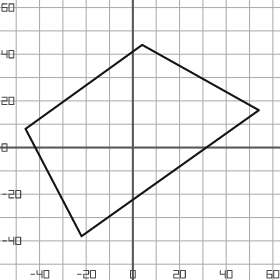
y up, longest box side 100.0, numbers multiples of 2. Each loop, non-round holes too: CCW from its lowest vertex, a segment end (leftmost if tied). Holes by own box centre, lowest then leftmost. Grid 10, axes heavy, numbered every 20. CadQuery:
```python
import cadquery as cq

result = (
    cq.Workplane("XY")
    .moveTo(-22.0, -38.0)
    .lineTo(54.0, 16.0)
    .lineTo(4.0, 44.0)
    .lineTo(-46.0, 8.0)
    .close()
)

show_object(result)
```